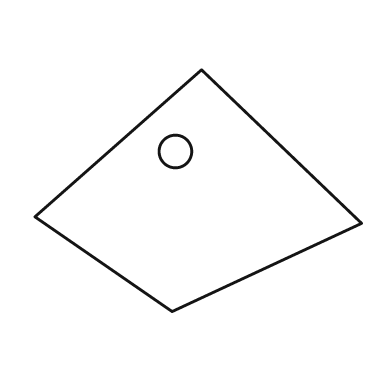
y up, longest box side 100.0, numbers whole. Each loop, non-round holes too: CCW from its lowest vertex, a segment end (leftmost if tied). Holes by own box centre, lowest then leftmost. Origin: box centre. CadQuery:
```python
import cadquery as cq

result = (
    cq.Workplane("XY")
    .moveTo(-8.0, -37.0)
    .lineTo(50.0, -10.0)
    .lineTo(1.0, 37.0)
    .lineTo(-50.0, -8.0)
    .close()
    .moveTo(-7.0, 12.0)
    .circle(5.0)
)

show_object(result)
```